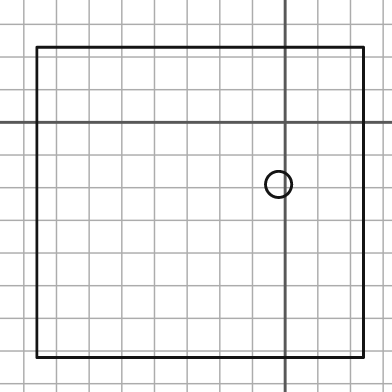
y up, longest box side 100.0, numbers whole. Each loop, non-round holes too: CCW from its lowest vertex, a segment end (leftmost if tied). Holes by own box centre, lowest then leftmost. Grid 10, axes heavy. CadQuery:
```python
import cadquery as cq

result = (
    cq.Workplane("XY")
    .moveTo(-76.0, -72.0)
    .lineTo(24.0, -72.0)
    .lineTo(24.0, 23.0)
    .lineTo(-76.0, 23.0)
    .close()
    .moveTo(-2.0, -19.0)
    .circle(4.0)
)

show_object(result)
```